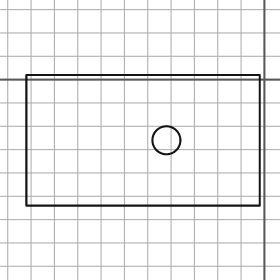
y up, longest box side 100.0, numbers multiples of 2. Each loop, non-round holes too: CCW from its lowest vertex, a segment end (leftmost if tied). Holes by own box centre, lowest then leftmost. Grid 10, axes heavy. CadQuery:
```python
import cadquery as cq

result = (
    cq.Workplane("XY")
    .moveTo(-102.0, -54.0)
    .lineTo(-2.0, -54.0)
    .lineTo(-2.0, 2.0)
    .lineTo(-102.0, 2.0)
    .close()
    .moveTo(-42.0, -26.0)
    .circle(6.0)
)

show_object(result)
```